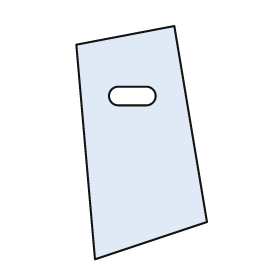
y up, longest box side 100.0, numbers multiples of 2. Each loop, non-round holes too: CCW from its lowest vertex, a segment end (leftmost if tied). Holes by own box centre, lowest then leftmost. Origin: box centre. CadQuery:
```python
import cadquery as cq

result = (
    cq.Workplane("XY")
    .moveTo(-20.0, -50.0)
    .lineTo(28.0, -34.0)
    .lineTo(14.0, 50.0)
    .lineTo(-28.0, 42.0)
    .close()
    .moveTo(-10.0, 16.0)
    .lineTo(2.0, 16.0)
    .threePointArc((6.0, 20.0), (2.0, 24.0))
    .lineTo(-10.0, 24.0)
    .threePointArc((-14.0, 20.0), (-10.0, 16.0))
    .close()
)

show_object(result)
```